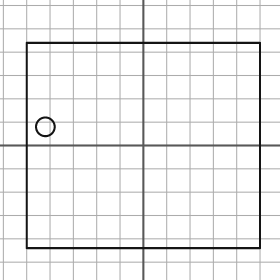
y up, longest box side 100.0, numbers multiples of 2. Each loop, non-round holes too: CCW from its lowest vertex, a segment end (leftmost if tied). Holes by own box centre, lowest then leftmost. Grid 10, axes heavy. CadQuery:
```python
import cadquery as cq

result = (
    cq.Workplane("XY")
    .moveTo(-50.0, -44.0)
    .lineTo(50.0, -44.0)
    .lineTo(50.0, 44.0)
    .lineTo(-50.0, 44.0)
    .close()
    .moveTo(-42.0, 8.0)
    .circle(4.0)
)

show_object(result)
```